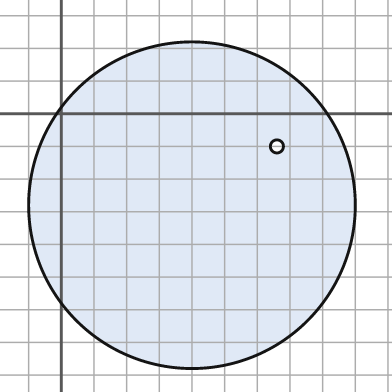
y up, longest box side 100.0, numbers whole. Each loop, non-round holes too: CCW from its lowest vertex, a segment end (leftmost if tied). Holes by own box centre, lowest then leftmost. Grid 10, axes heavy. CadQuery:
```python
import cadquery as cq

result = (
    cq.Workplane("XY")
    .moveTo(40.0, -28.0)
    .circle(50.0)
    .moveTo(66.0, -10.0)
    .circle(2.0)
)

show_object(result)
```